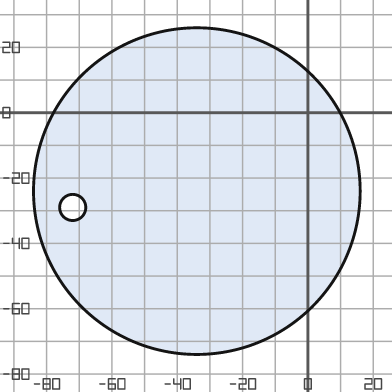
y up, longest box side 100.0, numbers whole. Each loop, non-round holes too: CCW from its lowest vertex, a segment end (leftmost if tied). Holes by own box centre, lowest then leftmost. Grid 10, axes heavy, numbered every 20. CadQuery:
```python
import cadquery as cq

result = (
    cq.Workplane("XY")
    .moveTo(-34.0, -24.0)
    .circle(50.0)
    .moveTo(-72.0, -29.0)
    .circle(4.0)
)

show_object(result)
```